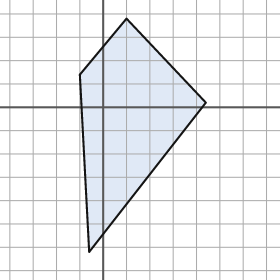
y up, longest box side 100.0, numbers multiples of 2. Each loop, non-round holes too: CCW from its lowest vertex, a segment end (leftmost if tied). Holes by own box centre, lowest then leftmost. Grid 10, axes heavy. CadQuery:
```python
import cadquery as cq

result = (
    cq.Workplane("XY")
    .moveTo(-6.0, -62.0)
    .lineTo(44.0, 2.0)
    .lineTo(10.0, 38.0)
    .lineTo(-10.0, 14.0)
    .close()
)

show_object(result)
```